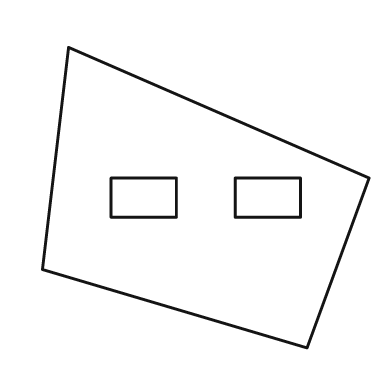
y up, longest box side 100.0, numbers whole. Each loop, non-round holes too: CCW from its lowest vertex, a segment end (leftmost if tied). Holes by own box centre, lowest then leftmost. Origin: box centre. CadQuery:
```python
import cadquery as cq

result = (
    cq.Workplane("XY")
    .moveTo(31.0, -46.0)
    .lineTo(50.0, 6.0)
    .lineTo(-42.0, 46.0)
    .lineTo(-50.0, -22.0)
    .close()
    .moveTo(-29.0, -6.0)
    .lineTo(-9.0, -6.0)
    .lineTo(-9.0, 6.0)
    .lineTo(-29.0, 6.0)
    .close()
    .moveTo(9.0, -6.0)
    .lineTo(29.0, -6.0)
    .lineTo(29.0, 6.0)
    .lineTo(9.0, 6.0)
    .close()
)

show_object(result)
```